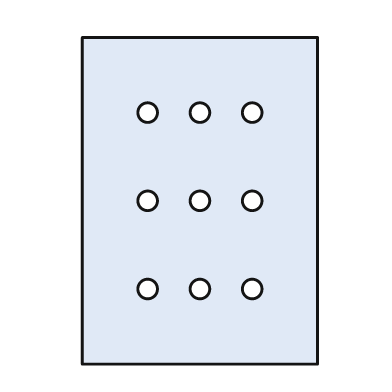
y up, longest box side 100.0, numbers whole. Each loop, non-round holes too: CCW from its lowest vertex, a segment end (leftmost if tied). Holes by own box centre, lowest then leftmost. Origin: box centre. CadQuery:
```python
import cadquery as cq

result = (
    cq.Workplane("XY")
    .moveTo(-36.0, -50.0)
    .lineTo(36.0, -50.0)
    .lineTo(36.0, 50.0)
    .lineTo(-36.0, 50.0)
    .close()
    .moveTo(-16.0, -27.0)
    .circle(3.0)
    .moveTo(0.0, -27.0)
    .circle(3.0)
    .moveTo(16.0, -27.0)
    .circle(3.0)
    .moveTo(-16.0, 0.0)
    .circle(3.0)
    .moveTo(0.0, 0.0)
    .circle(3.0)
    .moveTo(16.0, 0.0)
    .circle(3.0)
    .moveTo(-16.0, 27.0)
    .circle(3.0)
    .moveTo(0.0, 27.0)
    .circle(3.0)
    .moveTo(16.0, 27.0)
    .circle(3.0)
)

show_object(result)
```